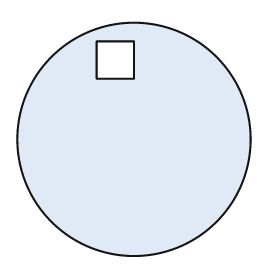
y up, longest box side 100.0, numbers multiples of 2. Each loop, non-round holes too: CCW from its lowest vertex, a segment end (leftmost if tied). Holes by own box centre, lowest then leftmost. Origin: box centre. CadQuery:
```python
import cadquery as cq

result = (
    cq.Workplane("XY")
    .moveTo(0.0, 0.0)
    .circle(50.0)
    .moveTo(-16.0, 26.0)
    .lineTo(0.0, 26.0)
    .lineTo(0.0, 42.0)
    .lineTo(-16.0, 42.0)
    .close()
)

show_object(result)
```